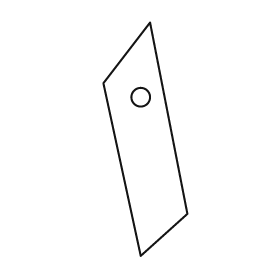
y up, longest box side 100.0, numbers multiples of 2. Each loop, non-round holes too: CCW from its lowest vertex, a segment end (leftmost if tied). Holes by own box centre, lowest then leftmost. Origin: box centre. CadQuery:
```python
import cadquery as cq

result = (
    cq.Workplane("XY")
    .moveTo(-2.0, -50.0)
    .lineTo(18.0, -32.0)
    .lineTo(2.0, 50.0)
    .lineTo(-18.0, 24.0)
    .close()
    .moveTo(-2.0, 18.0)
    .circle(4.0)
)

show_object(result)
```